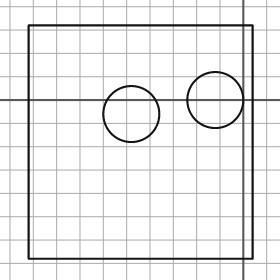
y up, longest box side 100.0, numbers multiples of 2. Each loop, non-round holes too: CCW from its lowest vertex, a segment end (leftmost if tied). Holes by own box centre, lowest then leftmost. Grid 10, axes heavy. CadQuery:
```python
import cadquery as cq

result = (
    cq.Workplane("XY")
    .moveTo(-92.0, -68.0)
    .lineTo(4.0, -68.0)
    .lineTo(4.0, 32.0)
    .lineTo(-92.0, 32.0)
    .close()
    .moveTo(-48.0, -6.0)
    .circle(12.0)
    .moveTo(-12.0, 0.0)
    .circle(12.0)
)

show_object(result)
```